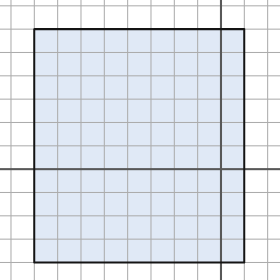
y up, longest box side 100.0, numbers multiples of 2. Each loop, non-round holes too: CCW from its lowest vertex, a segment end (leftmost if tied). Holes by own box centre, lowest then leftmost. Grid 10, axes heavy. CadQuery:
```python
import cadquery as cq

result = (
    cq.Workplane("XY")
    .moveTo(-80.0, -40.0)
    .lineTo(10.0, -40.0)
    .lineTo(10.0, 60.0)
    .lineTo(-80.0, 60.0)
    .close()
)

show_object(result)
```